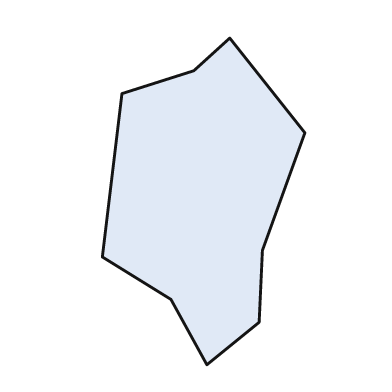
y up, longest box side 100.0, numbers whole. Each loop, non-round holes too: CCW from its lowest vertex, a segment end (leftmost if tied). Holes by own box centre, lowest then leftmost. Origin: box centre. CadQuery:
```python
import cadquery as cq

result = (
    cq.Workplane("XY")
    .moveTo(1.0, -50.0)
    .lineTo(17.0, -37.0)
    .lineTo(18.0, -15.0)
    .lineTo(31.0, 21.0)
    .lineTo(8.0, 50.0)
    .lineTo(-3.0, 40.0)
    .lineTo(-25.0, 33.0)
    .lineTo(-31.0, -17.0)
    .lineTo(-10.0, -30.0)
    .close()
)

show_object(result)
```